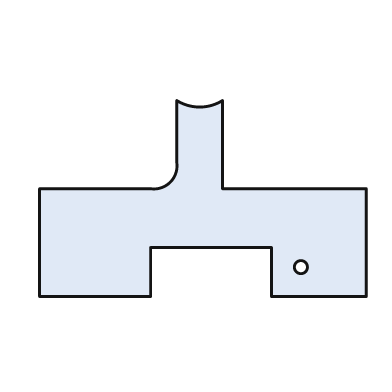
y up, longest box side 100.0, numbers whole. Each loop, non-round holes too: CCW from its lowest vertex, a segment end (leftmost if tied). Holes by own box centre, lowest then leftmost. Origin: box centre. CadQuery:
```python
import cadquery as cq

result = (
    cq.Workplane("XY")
    .moveTo(-50.0, -30.0)
    .lineTo(-16.0, -30.0)
    .lineTo(-16.0, -15.0)
    .lineTo(21.0, -15.0)
    .lineTo(21.0, -30.0)
    .lineTo(50.0, -30.0)
    .lineTo(50.0, 3.0)
    .lineTo(6.0, 3.0)
    .lineTo(6.0, 30.0)
    .threePointArc((-1.0, 28.0), (-8.0, 30.0))
    .lineTo(-8.0, 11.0)
    .threePointArc((-10.0, 5.0), (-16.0, 3.0))
    .lineTo(-50.0, 3.0)
    .close()
    .moveTo(30.0, -21.0)
    .circle(2.0)
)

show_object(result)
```